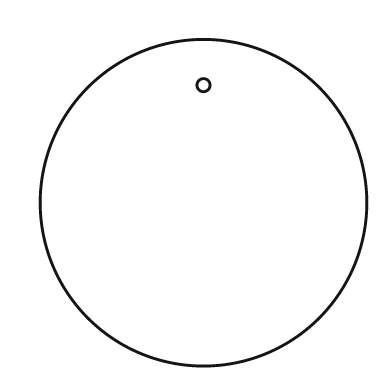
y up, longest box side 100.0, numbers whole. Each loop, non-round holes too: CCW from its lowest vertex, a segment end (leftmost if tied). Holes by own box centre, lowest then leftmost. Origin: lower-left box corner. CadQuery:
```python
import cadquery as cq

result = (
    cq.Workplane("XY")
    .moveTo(50.0, 50.0)
    .circle(50.0)
    .moveTo(50.0, 86.0)
    .circle(2.0)
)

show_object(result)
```